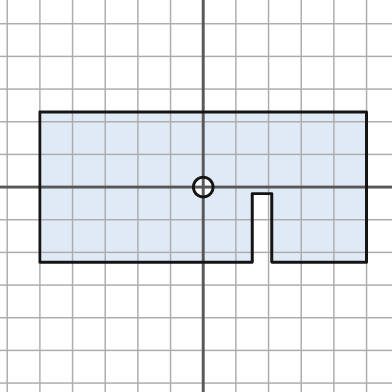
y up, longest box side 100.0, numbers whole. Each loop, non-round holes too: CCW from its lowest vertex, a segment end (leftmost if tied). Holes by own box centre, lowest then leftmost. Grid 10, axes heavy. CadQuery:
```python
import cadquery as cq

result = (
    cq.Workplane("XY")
    .moveTo(-50.0, -23.0)
    .lineTo(15.0, -23.0)
    .lineTo(15.0, -2.0)
    .lineTo(21.0, -2.0)
    .lineTo(21.0, -23.0)
    .lineTo(50.0, -23.0)
    .lineTo(50.0, 23.0)
    .lineTo(-50.0, 23.0)
    .close()
    .moveTo(0.0, 0.0)
    .circle(3.0)
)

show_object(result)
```